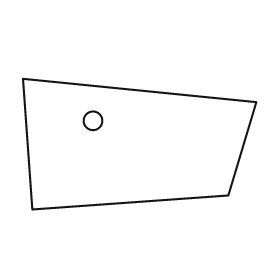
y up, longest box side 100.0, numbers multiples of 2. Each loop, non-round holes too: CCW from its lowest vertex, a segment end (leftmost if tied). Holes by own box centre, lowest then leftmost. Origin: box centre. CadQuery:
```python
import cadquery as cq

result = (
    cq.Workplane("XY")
    .moveTo(-46.0, -28.0)
    .lineTo(38.0, -22.0)
    .lineTo(50.0, 18.0)
    .lineTo(-50.0, 28.0)
    .close()
    .moveTo(-20.0, 10.0)
    .circle(4.0)
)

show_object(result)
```